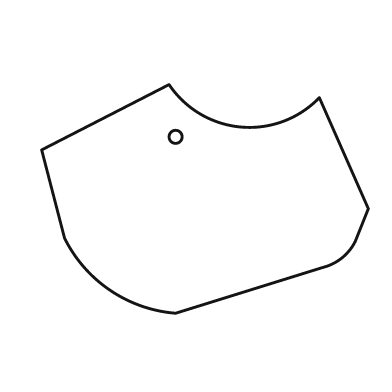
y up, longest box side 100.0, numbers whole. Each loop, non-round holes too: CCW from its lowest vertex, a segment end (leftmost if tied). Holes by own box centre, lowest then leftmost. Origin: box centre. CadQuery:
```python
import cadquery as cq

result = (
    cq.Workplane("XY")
    .moveTo(-9.0, -35.0)
    .lineTo(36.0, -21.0)
    .threePointArc((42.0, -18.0), (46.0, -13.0))
    .lineTo(50.0, -3.0)
    .lineTo(35.0, 31.0)
    .threePointArc((11.0, 22.0), (-11.0, 35.0))
    .lineTo(-50.0, 15.0)
    .lineTo(-43.0, -12.0)
    .threePointArc((-29.0, -28.0), (-9.0, -35.0))
    .close()
    .moveTo(-9.0, 19.0)
    .circle(2.0)
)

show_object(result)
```